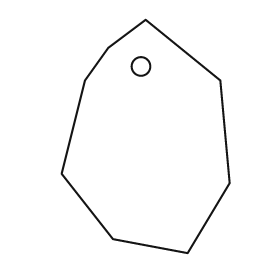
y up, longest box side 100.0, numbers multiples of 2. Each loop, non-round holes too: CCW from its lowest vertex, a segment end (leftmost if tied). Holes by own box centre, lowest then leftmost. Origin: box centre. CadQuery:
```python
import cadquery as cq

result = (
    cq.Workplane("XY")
    .moveTo(18.0, -50.0)
    .lineTo(36.0, -20.0)
    .lineTo(32.0, 24.0)
    .lineTo(0.0, 50.0)
    .lineTo(-16.0, 38.0)
    .lineTo(-26.0, 24.0)
    .lineTo(-36.0, -16.0)
    .lineTo(-14.0, -44.0)
    .close()
    .moveTo(-2.0, 30.0)
    .circle(4.0)
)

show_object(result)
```